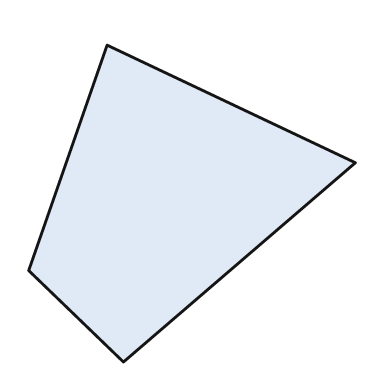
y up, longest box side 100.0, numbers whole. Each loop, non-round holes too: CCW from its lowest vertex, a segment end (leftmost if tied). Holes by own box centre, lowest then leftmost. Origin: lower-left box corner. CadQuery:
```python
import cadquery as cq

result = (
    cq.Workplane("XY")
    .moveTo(29.0, 0.0)
    .lineTo(100.0, 61.0)
    .lineTo(24.0, 97.0)
    .lineTo(0.0, 28.0)
    .close()
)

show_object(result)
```